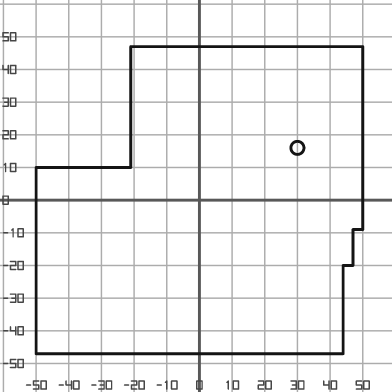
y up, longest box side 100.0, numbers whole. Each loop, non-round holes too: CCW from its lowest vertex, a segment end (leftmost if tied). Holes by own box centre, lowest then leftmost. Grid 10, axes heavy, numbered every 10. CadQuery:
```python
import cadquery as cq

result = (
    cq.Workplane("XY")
    .moveTo(-50.0, -47.0)
    .lineTo(44.0, -47.0)
    .lineTo(44.0, -20.0)
    .lineTo(47.0, -20.0)
    .lineTo(47.0, -9.0)
    .lineTo(50.0, -9.0)
    .lineTo(50.0, 47.0)
    .lineTo(-21.0, 47.0)
    .lineTo(-21.0, 10.0)
    .lineTo(-50.0, 10.0)
    .close()
    .moveTo(30.0, 16.0)
    .circle(2.0)
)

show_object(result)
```